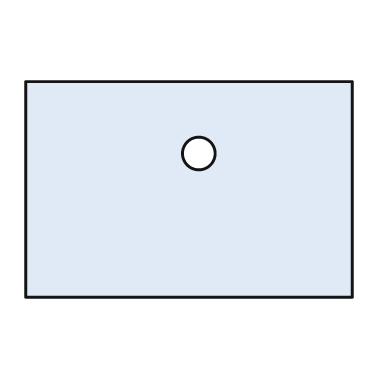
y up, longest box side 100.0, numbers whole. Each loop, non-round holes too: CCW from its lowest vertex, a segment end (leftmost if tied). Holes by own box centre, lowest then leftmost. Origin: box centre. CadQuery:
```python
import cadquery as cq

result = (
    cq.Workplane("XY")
    .moveTo(-50.0, -33.0)
    .lineTo(50.0, -33.0)
    .lineTo(50.0, 33.0)
    .lineTo(-50.0, 33.0)
    .close()
    .moveTo(3.0, 11.0)
    .circle(5.0)
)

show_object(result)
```